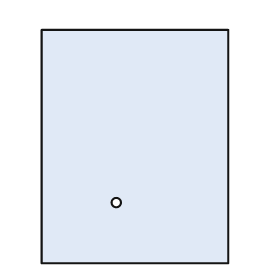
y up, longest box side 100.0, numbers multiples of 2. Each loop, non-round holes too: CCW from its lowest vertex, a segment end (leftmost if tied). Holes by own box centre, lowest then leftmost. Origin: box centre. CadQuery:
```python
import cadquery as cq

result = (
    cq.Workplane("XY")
    .moveTo(-40.0, -50.0)
    .lineTo(40.0, -50.0)
    .lineTo(40.0, 50.0)
    .lineTo(-40.0, 50.0)
    .close()
    .moveTo(-8.0, -24.0)
    .circle(2.0)
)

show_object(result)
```